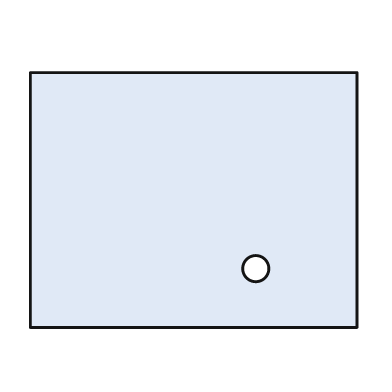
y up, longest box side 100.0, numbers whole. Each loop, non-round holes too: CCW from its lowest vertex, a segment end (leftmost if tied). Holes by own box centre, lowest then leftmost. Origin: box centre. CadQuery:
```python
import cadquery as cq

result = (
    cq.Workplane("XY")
    .moveTo(-50.0, -39.0)
    .lineTo(50.0, -39.0)
    .lineTo(50.0, 39.0)
    .lineTo(-50.0, 39.0)
    .close()
    .moveTo(19.0, -21.0)
    .circle(4.0)
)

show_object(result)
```